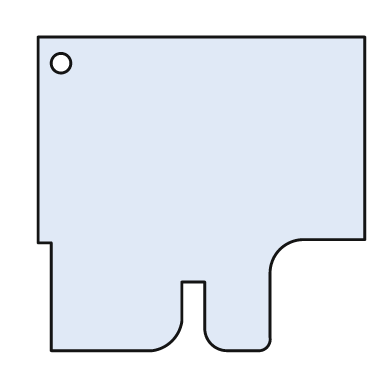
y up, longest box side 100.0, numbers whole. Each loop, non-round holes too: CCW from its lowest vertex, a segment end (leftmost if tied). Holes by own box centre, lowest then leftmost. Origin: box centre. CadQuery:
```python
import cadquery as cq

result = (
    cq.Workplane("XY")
    .moveTo(-46.0, -48.0)
    .lineTo(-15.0, -48.0)
    .threePointArc((-9.0, -45.0), (-6.0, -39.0))
    .lineTo(-6.0, -27.0)
    .lineTo(1.0, -27.0)
    .lineTo(1.0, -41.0)
    .threePointArc((3.0, -46.0), (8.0, -48.0))
    .lineTo(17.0, -48.0)
    .threePointArc((20.0, -47.0), (21.0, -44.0))
    .lineTo(21.0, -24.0)
    .threePointArc((24.0, -17.0), (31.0, -14.0))
    .lineTo(50.0, -14.0)
    .lineTo(50.0, 48.0)
    .lineTo(-50.0, 48.0)
    .lineTo(-50.0, -15.0)
    .lineTo(-46.0, -15.0)
    .close()
    .moveTo(-43.0, 40.0)
    .circle(3.0)
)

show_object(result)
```